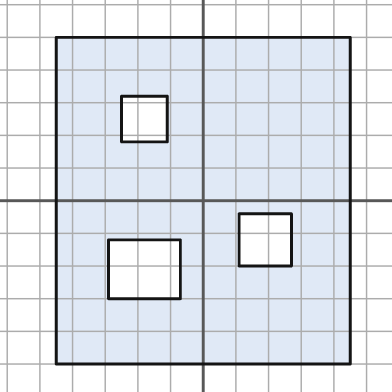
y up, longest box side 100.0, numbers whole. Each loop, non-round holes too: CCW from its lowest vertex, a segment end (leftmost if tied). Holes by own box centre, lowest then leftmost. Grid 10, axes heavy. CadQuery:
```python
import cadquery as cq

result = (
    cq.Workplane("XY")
    .moveTo(-45.0, -50.0)
    .lineTo(45.0, -50.0)
    .lineTo(45.0, 50.0)
    .lineTo(-45.0, 50.0)
    .close()
    .moveTo(-29.0, -30.0)
    .lineTo(-7.0, -30.0)
    .lineTo(-7.0, -12.0)
    .lineTo(-29.0, -12.0)
    .close()
    .moveTo(11.0, -20.0)
    .lineTo(27.0, -20.0)
    .lineTo(27.0, -4.0)
    .lineTo(11.0, -4.0)
    .close()
    .moveTo(-25.0, 18.0)
    .lineTo(-11.0, 18.0)
    .lineTo(-11.0, 32.0)
    .lineTo(-25.0, 32.0)
    .close()
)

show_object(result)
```